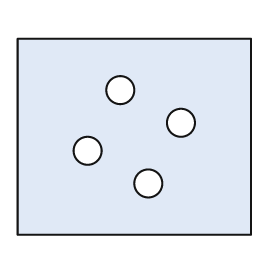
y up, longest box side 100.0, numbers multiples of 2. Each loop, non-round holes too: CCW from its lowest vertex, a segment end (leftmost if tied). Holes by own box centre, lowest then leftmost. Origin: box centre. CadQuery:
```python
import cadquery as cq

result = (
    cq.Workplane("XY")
    .moveTo(-50.0, -42.0)
    .lineTo(50.0, -42.0)
    .lineTo(50.0, 42.0)
    .lineTo(-50.0, 42.0)
    .close()
    .moveTo(6.0, -20.0)
    .circle(6.0)
    .moveTo(-20.0, -6.0)
    .circle(6.0)
    .moveTo(20.0, 6.0)
    .circle(6.0)
    .moveTo(-6.0, 20.0)
    .circle(6.0)
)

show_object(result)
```